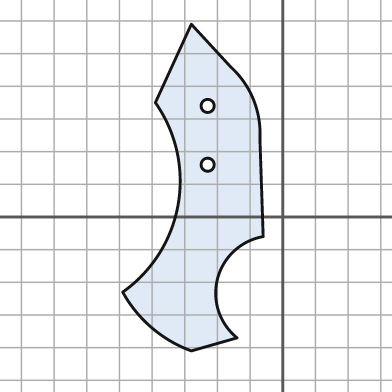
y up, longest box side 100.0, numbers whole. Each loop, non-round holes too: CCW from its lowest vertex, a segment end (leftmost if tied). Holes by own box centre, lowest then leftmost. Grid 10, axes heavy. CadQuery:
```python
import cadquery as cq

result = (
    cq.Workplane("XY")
    .moveTo(-28.0, -41.0)
    .lineTo(-14.0, -37.0)
    .threePointArc((-20.0, -19.0), (-6.0, -6.0))
    .lineTo(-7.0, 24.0)
    .threePointArc((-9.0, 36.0), (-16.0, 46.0))
    .lineTo(-28.0, 59.0)
    .lineTo(-39.0, 35.0)
    .threePointArc((-32.0, 4.0), (-49.0, -23.0))
    .threePointArc((-40.0, -34.0), (-28.0, -41.0))
    .close()
    .moveTo(-23.0, 16.0)
    .circle(2.0)
    .moveTo(-23.0, 34.0)
    .circle(2.0)
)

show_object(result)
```